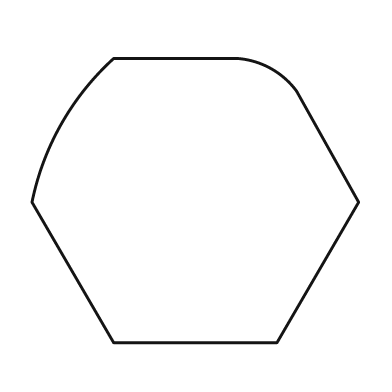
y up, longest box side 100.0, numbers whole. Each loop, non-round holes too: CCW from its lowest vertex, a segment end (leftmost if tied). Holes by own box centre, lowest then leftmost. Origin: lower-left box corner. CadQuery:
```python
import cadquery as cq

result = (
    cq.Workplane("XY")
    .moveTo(25.0, 0.0)
    .lineTo(75.0, 0.0)
    .lineTo(100.0, 43.0)
    .lineTo(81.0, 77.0)
    .threePointArc((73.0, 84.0), (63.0, 87.0))
    .lineTo(25.0, 87.0)
    .threePointArc((9.0, 67.0), (0.0, 43.0))
    .close()
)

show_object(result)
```